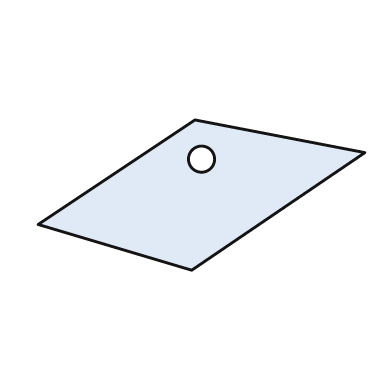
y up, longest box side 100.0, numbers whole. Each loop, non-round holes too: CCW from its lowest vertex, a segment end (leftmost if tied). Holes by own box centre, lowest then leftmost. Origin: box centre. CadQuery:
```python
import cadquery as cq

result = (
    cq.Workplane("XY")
    .moveTo(-3.0, -23.0)
    .lineTo(50.0, 13.0)
    .lineTo(-2.0, 23.0)
    .lineTo(-50.0, -9.0)
    .close()
    .moveTo(0.0, 11.0)
    .circle(4.0)
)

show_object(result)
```